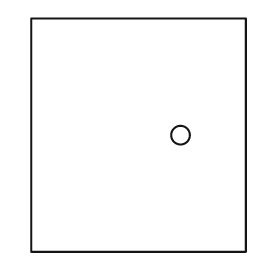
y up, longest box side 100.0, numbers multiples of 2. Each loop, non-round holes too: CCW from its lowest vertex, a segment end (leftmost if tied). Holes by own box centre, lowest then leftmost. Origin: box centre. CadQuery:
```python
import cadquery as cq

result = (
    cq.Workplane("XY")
    .moveTo(-46.0, -50.0)
    .lineTo(46.0, -50.0)
    .lineTo(46.0, 50.0)
    .lineTo(-46.0, 50.0)
    .close()
    .moveTo(18.0, 0.0)
    .circle(4.0)
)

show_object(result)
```